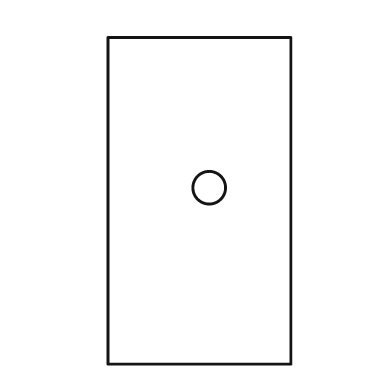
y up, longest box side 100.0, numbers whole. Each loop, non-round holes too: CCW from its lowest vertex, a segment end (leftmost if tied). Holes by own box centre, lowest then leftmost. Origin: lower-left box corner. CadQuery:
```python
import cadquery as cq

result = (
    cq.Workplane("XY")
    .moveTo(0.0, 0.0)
    .lineTo(56.0, 0.0)
    .lineTo(56.0, 100.0)
    .lineTo(0.0, 100.0)
    .close()
    .moveTo(31.0, 54.0)
    .circle(5.0)
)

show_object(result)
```